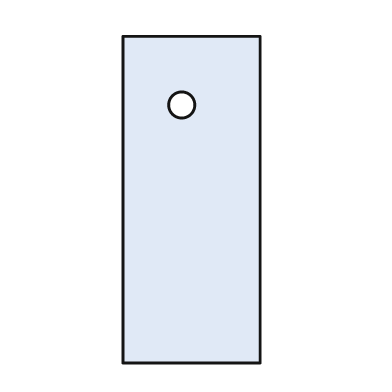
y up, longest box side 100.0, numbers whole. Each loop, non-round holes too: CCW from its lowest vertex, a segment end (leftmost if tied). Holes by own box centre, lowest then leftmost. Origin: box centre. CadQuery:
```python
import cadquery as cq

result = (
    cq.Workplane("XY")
    .moveTo(-21.0, -50.0)
    .lineTo(21.0, -50.0)
    .lineTo(21.0, 50.0)
    .lineTo(-21.0, 50.0)
    .close()
    .moveTo(-3.0, 29.0)
    .circle(4.0)
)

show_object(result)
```